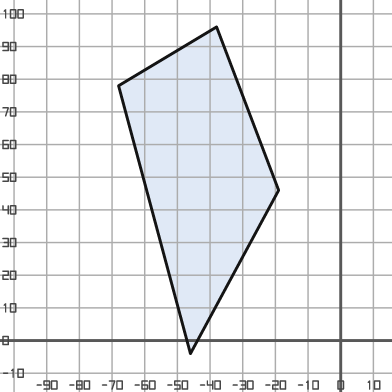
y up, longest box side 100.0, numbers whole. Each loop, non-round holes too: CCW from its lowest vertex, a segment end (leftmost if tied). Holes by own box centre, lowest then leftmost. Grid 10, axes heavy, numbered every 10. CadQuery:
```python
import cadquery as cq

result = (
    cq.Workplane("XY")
    .moveTo(-46.0, -4.0)
    .lineTo(-19.0, 46.0)
    .lineTo(-38.0, 96.0)
    .lineTo(-68.0, 78.0)
    .close()
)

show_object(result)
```